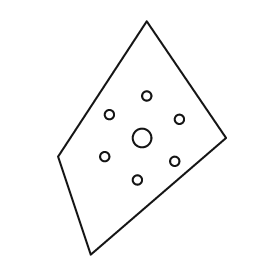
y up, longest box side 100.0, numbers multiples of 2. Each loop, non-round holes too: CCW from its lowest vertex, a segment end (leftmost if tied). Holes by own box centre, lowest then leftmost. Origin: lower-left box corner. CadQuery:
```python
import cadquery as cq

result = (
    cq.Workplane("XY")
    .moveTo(14.0, 0.0)
    .lineTo(72.0, 50.0)
    .lineTo(38.0, 100.0)
    .lineTo(0.0, 42.0)
    .close()
    .moveTo(34.0, 32.0)
    .circle(2.0)
    .moveTo(50.0, 40.0)
    .circle(2.0)
    .moveTo(20.0, 42.0)
    .circle(2.0)
    .moveTo(36.0, 50.0)
    .circle(4.0)
    .moveTo(52.0, 58.0)
    .circle(2.0)
    .moveTo(22.0, 60.0)
    .circle(2.0)
    .moveTo(38.0, 68.0)
    .circle(2.0)
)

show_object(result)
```